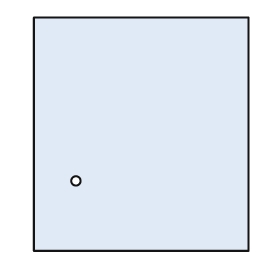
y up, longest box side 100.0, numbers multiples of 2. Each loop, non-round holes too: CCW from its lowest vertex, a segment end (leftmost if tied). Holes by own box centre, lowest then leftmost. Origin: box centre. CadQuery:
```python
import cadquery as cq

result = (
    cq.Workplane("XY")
    .moveTo(-46.0, -50.0)
    .lineTo(46.0, -50.0)
    .lineTo(46.0, 50.0)
    .lineTo(-46.0, 50.0)
    .close()
    .moveTo(-28.0, -20.0)
    .circle(2.0)
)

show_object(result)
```